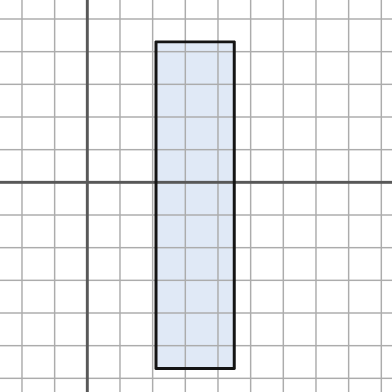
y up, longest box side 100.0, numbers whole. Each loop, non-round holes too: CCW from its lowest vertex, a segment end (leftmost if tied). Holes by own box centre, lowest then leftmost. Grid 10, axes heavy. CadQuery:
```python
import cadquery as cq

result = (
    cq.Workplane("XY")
    .moveTo(21.0, -57.0)
    .lineTo(45.0, -57.0)
    .lineTo(45.0, 43.0)
    .lineTo(21.0, 43.0)
    .close()
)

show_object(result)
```